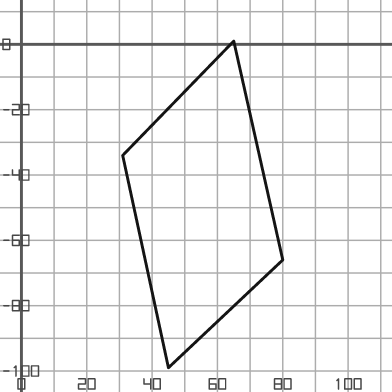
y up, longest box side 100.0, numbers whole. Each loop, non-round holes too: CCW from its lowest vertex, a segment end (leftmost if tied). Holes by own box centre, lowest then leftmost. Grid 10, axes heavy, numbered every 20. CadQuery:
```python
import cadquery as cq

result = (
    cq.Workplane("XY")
    .moveTo(45.0, -99.0)
    .lineTo(80.0, -66.0)
    .lineTo(65.0, 1.0)
    .lineTo(31.0, -34.0)
    .close()
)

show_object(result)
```